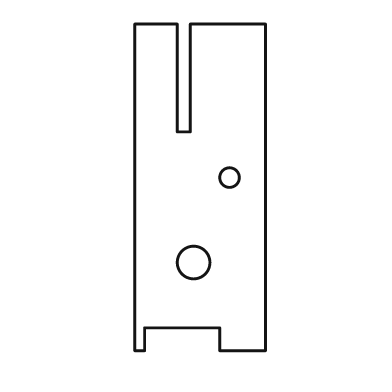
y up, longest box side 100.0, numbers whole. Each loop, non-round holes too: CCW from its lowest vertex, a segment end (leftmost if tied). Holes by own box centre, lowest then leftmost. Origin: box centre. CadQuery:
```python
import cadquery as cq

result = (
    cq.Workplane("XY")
    .moveTo(-20.0, -50.0)
    .lineTo(-17.0, -50.0)
    .lineTo(-17.0, -43.0)
    .lineTo(6.0, -43.0)
    .lineTo(6.0, -50.0)
    .lineTo(20.0, -50.0)
    .lineTo(20.0, 50.0)
    .lineTo(-3.0, 50.0)
    .lineTo(-3.0, 17.0)
    .lineTo(-7.0, 17.0)
    .lineTo(-7.0, 50.0)
    .lineTo(-20.0, 50.0)
    .close()
    .moveTo(-2.0, -23.0)
    .circle(5.0)
    .moveTo(9.0, 3.0)
    .circle(3.0)
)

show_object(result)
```